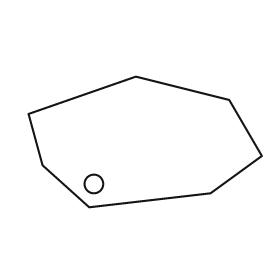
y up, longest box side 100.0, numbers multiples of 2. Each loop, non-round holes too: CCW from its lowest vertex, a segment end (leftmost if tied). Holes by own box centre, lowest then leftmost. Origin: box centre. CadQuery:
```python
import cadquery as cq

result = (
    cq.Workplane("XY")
    .moveTo(-24.0, -28.0)
    .lineTo(28.0, -22.0)
    .lineTo(50.0, -6.0)
    .lineTo(36.0, 18.0)
    .lineTo(-4.0, 28.0)
    .lineTo(-50.0, 12.0)
    .lineTo(-44.0, -10.0)
    .close()
    .moveTo(-22.0, -18.0)
    .circle(4.0)
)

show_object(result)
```